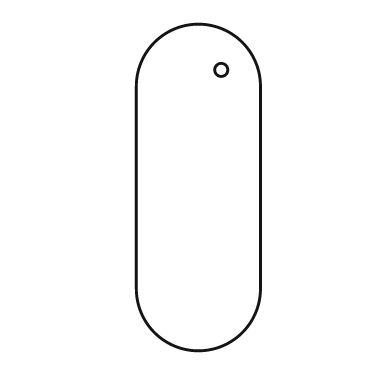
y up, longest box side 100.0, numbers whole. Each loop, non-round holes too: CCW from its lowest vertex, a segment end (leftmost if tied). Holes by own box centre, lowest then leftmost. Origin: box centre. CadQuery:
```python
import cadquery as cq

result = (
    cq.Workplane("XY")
    .moveTo(-19.0, -31.0)
    .threePointArc((0.0, -50.0), (19.0, -31.0))
    .lineTo(19.0, 31.0)
    .threePointArc((0.0, 50.0), (-19.0, 31.0))
    .close()
    .moveTo(7.0, 36.0)
    .circle(2.0)
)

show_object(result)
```